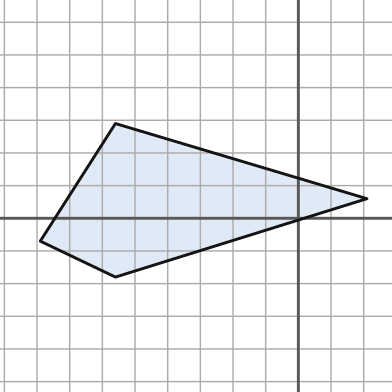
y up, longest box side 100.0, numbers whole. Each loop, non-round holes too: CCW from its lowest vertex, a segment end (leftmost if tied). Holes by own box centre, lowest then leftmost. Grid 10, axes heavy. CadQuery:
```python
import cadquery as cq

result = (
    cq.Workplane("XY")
    .moveTo(-56.0, -18.0)
    .lineTo(21.0, 6.0)
    .lineTo(-56.0, 29.0)
    .lineTo(-79.0, -7.0)
    .close()
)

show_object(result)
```